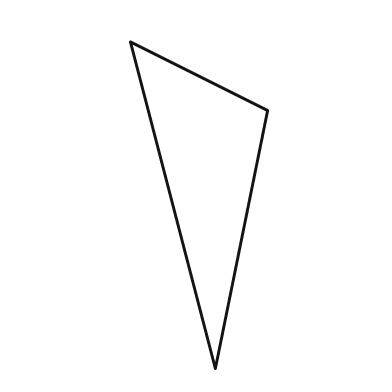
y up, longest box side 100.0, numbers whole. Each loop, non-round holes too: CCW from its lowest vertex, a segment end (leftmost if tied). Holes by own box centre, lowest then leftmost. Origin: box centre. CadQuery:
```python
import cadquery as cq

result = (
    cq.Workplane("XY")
    .moveTo(5.0, -50.0)
    .lineTo(21.0, 29.0)
    .lineTo(-21.0, 50.0)
    .close()
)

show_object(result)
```